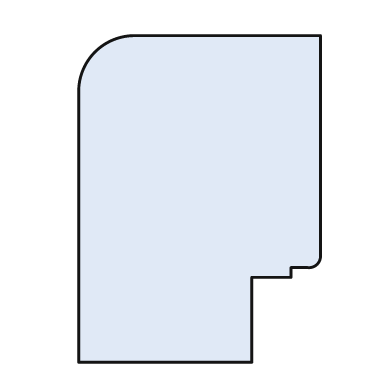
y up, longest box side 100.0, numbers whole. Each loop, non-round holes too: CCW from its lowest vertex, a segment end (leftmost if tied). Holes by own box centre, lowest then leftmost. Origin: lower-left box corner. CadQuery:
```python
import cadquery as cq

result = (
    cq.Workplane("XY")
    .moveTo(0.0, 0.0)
    .lineTo(53.0, 0.0)
    .lineTo(53.0, 26.0)
    .lineTo(65.0, 26.0)
    .lineTo(65.0, 29.0)
    .lineTo(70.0, 29.0)
    .threePointArc((73.0, 30.0), (74.0, 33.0))
    .lineTo(74.0, 100.0)
    .lineTo(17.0, 100.0)
    .threePointArc((5.0, 95.0), (0.0, 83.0))
    .close()
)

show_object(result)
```